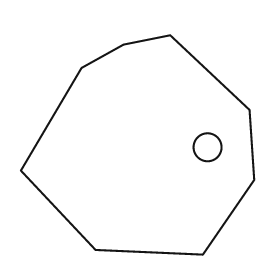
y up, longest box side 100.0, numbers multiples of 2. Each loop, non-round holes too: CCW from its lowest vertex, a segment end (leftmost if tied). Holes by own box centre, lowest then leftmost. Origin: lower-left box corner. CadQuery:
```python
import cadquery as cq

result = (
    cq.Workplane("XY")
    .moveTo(78.0, 0.0)
    .lineTo(100.0, 32.0)
    .lineTo(98.0, 62.0)
    .lineTo(64.0, 94.0)
    .lineTo(44.0, 90.0)
    .lineTo(26.0, 80.0)
    .lineTo(0.0, 36.0)
    .lineTo(32.0, 2.0)
    .close()
    .moveTo(80.0, 46.0)
    .circle(6.0)
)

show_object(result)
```